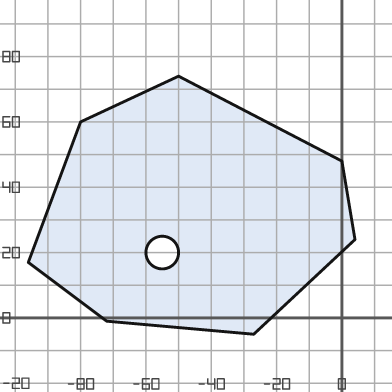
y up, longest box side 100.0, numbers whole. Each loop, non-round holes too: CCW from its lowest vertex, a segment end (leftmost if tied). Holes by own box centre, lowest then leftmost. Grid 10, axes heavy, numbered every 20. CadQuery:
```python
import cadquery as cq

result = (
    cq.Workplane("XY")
    .moveTo(-27.0, -5.0)
    .lineTo(4.0, 24.0)
    .lineTo(0.0, 48.0)
    .lineTo(-50.0, 74.0)
    .lineTo(-80.0, 60.0)
    .lineTo(-96.0, 17.0)
    .lineTo(-72.0, -1.0)
    .close()
    .moveTo(-55.0, 20.0)
    .circle(5.0)
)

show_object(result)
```